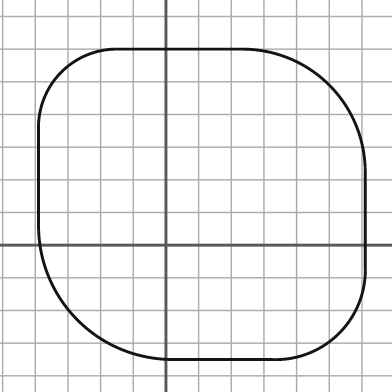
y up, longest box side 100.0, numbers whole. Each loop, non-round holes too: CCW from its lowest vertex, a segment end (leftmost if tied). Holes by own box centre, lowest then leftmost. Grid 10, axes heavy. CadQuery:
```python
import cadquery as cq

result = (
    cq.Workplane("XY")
    .moveTo(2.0, -35.0)
    .lineTo(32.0, -35.0)
    .threePointArc((53.0, -27.0), (61.0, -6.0))
    .lineTo(61.0, 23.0)
    .threePointArc((50.0, 49.0), (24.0, 60.0))
    .lineTo(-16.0, 60.0)
    .threePointArc((-32.0, 53.0), (-39.0, 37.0))
    .lineTo(-39.0, 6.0)
    .threePointArc((-27.0, -23.0), (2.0, -35.0))
    .close()
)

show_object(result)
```